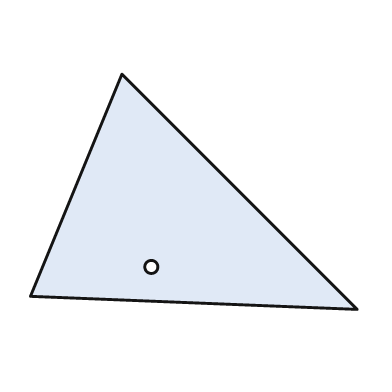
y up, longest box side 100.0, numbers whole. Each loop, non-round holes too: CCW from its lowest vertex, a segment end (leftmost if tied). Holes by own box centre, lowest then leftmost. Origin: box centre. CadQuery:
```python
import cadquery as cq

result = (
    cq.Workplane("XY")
    .moveTo(50.0, -36.0)
    .lineTo(-22.0, 36.0)
    .lineTo(-50.0, -32.0)
    .close()
    .moveTo(-13.0, -23.0)
    .circle(2.0)
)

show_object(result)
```